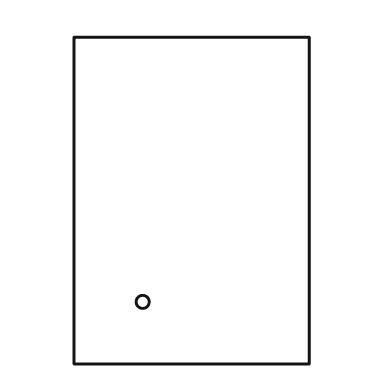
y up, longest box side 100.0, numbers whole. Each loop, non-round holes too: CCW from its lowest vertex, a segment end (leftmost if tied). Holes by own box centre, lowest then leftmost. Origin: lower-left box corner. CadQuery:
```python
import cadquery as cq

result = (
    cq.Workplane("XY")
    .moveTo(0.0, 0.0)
    .lineTo(72.0, 0.0)
    .lineTo(72.0, 100.0)
    .lineTo(0.0, 100.0)
    .close()
    .moveTo(21.0, 19.0)
    .circle(2.0)
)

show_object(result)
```